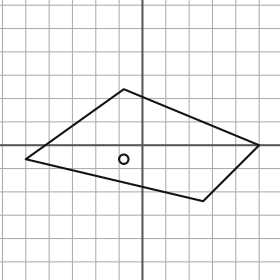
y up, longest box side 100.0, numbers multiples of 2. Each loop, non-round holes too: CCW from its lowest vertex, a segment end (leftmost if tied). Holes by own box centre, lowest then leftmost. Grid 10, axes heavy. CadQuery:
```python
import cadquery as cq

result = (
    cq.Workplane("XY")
    .moveTo(26.0, -24.0)
    .lineTo(50.0, 0.0)
    .lineTo(-8.0, 24.0)
    .lineTo(-50.0, -6.0)
    .close()
    .moveTo(-8.0, -6.0)
    .circle(2.0)
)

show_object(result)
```